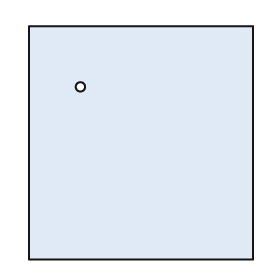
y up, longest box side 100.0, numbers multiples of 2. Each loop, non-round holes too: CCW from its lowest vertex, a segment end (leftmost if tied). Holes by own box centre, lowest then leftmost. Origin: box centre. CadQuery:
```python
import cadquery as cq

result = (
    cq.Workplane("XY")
    .moveTo(-48.0, -50.0)
    .lineTo(48.0, -50.0)
    .lineTo(48.0, 50.0)
    .lineTo(-48.0, 50.0)
    .close()
    .moveTo(-26.0, 24.0)
    .circle(2.0)
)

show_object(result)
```